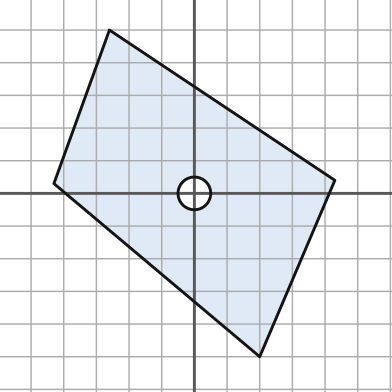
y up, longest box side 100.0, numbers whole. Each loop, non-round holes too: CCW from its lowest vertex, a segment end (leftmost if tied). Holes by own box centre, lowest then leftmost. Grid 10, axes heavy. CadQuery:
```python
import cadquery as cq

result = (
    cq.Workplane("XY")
    .moveTo(20.0, -50.0)
    .lineTo(43.0, 4.0)
    .lineTo(-26.0, 50.0)
    .lineTo(-43.0, 3.0)
    .close()
    .moveTo(0.0, 0.0)
    .circle(5.0)
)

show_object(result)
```